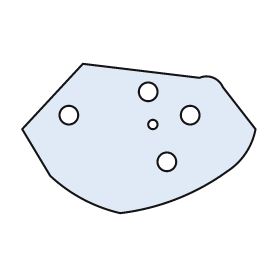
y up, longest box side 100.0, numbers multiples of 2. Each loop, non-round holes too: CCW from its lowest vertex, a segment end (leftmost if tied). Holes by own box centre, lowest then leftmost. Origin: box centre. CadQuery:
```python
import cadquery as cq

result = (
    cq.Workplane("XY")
    .moveTo(-8.0, -32.0)
    .threePointArc((16.0, -26.0), (38.0, -14.0))
    .threePointArc((46.0, -6.0), (50.0, 4.0))
    .lineTo(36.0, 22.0)
    .threePointArc((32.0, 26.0), (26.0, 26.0))
    .lineTo(-24.0, 32.0)
    .lineTo(-50.0, 4.0)
    .lineTo(-38.0, -16.0)
    .threePointArc((-24.0, -26.0), (-8.0, -32.0))
    .close()
    .moveTo(12.0, -10.0)
    .circle(4.0)
    .moveTo(6.0, 6.0)
    .circle(2.0)
    .moveTo(-30.0, 10.0)
    .circle(4.0)
    .moveTo(22.0, 10.0)
    .circle(4.0)
    .moveTo(4.0, 20.0)
    .circle(4.0)
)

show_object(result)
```